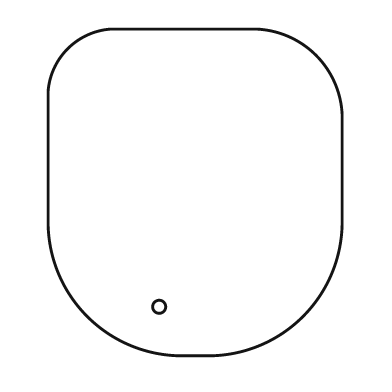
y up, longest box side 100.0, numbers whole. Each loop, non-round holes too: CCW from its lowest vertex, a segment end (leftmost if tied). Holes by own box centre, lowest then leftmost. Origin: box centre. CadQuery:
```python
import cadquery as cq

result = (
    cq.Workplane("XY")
    .moveTo(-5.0, -50.0)
    .lineTo(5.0, -50.0)
    .threePointArc((33.0, -38.0), (45.0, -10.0))
    .lineTo(45.0, 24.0)
    .threePointArc((37.0, 42.0), (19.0, 50.0))
    .lineTo(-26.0, 50.0)
    .threePointArc((-39.0, 44.0), (-45.0, 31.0))
    .lineTo(-45.0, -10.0)
    .threePointArc((-33.0, -38.0), (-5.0, -50.0))
    .close()
    .moveTo(-11.0, -35.0)
    .circle(2.0)
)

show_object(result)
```